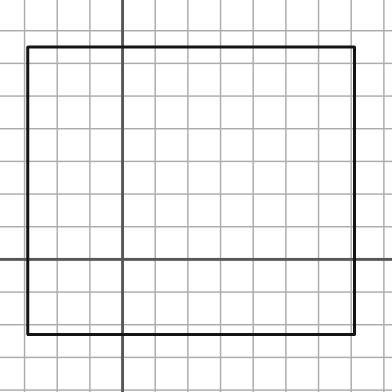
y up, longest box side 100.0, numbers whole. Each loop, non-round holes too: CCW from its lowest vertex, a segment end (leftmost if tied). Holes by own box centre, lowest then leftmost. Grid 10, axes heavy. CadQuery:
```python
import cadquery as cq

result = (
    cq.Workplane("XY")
    .moveTo(-29.0, -23.0)
    .lineTo(71.0, -23.0)
    .lineTo(71.0, 65.0)
    .lineTo(-29.0, 65.0)
    .close()
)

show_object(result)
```